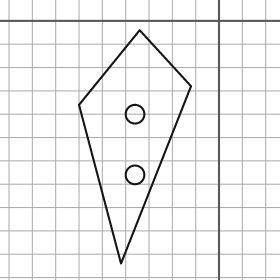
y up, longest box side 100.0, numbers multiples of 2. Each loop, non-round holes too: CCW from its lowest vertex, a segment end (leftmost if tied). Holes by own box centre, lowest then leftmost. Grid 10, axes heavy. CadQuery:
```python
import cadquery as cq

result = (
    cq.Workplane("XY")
    .moveTo(-42.0, -104.0)
    .lineTo(-12.0, -28.0)
    .lineTo(-34.0, -4.0)
    .lineTo(-60.0, -36.0)
    .close()
    .moveTo(-36.0, -66.0)
    .circle(4.0)
    .moveTo(-36.0, -40.0)
    .circle(4.0)
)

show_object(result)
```